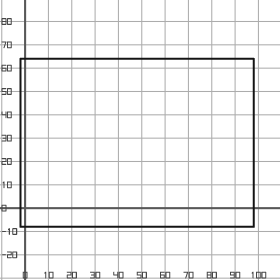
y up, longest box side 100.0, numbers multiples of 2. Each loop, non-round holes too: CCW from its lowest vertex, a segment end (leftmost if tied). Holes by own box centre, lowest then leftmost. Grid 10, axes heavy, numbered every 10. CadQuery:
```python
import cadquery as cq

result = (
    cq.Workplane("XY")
    .moveTo(-2.0, -8.0)
    .lineTo(98.0, -8.0)
    .lineTo(98.0, 64.0)
    .lineTo(-2.0, 64.0)
    .close()
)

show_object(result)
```